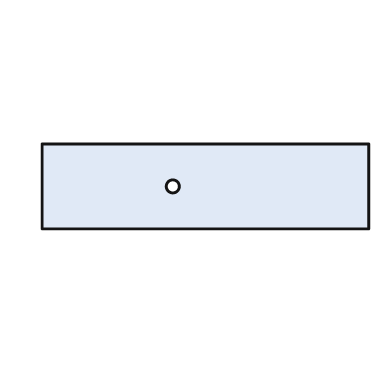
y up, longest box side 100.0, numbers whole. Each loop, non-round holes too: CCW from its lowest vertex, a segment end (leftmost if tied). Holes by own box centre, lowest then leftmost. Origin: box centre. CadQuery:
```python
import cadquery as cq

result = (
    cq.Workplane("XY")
    .moveTo(-50.0, -13.0)
    .lineTo(50.0, -13.0)
    .lineTo(50.0, 13.0)
    .lineTo(-50.0, 13.0)
    .close()
    .moveTo(-10.0, 0.0)
    .circle(2.0)
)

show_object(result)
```